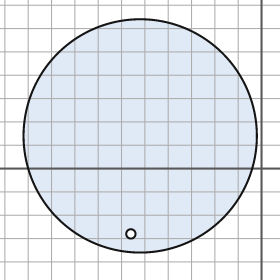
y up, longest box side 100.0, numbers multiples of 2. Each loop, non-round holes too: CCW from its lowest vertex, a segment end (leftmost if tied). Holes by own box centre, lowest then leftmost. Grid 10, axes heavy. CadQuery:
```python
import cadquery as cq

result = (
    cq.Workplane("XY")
    .moveTo(-52.0, 14.0)
    .circle(50.0)
    .moveTo(-56.0, -28.0)
    .circle(2.0)
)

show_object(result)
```